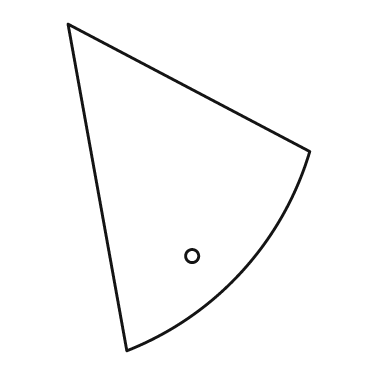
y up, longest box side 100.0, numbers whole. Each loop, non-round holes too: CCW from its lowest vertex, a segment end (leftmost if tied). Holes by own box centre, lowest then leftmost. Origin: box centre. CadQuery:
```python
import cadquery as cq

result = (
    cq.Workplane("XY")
    .moveTo(-19.0, -50.0)
    .threePointArc((16.0, -26.0), (37.0, 11.0))
    .lineTo(-37.0, 50.0)
    .close()
    .moveTo(1.0, -21.0)
    .circle(2.0)
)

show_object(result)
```